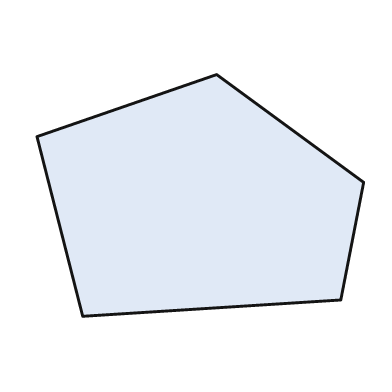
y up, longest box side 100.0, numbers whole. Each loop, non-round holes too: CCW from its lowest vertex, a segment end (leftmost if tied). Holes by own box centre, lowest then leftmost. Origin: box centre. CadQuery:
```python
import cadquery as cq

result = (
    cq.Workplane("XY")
    .moveTo(-36.0, -37.0)
    .lineTo(43.0, -32.0)
    .lineTo(50.0, 4.0)
    .lineTo(5.0, 37.0)
    .lineTo(-50.0, 18.0)
    .close()
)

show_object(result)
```